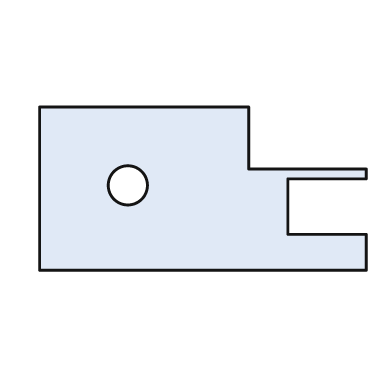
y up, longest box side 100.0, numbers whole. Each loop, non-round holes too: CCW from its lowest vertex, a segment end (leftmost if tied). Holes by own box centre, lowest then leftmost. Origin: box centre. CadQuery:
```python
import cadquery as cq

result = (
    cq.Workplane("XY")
    .moveTo(-50.0, -25.0)
    .lineTo(50.0, -25.0)
    .lineTo(50.0, -14.0)
    .lineTo(26.0, -14.0)
    .lineTo(26.0, 3.0)
    .lineTo(50.0, 3.0)
    .lineTo(50.0, 6.0)
    .lineTo(14.0, 6.0)
    .lineTo(14.0, 25.0)
    .lineTo(-50.0, 25.0)
    .close()
    .moveTo(-23.0, 1.0)
    .circle(6.0)
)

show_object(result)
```